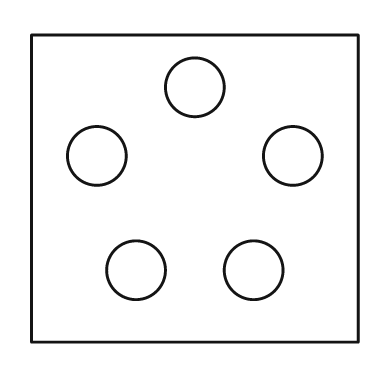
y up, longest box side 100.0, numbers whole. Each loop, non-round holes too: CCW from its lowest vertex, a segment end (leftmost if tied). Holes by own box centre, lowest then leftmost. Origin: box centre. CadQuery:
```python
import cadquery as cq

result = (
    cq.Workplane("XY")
    .moveTo(-50.0, -47.0)
    .lineTo(50.0, -47.0)
    .lineTo(50.0, 47.0)
    .lineTo(-50.0, 47.0)
    .close()
    .moveTo(-18.0, -25.0)
    .circle(9.0)
    .moveTo(18.0, -25.0)
    .circle(9.0)
    .moveTo(-30.0, 10.0)
    .circle(9.0)
    .moveTo(30.0, 10.0)
    .circle(9.0)
    .moveTo(0.0, 31.0)
    .circle(9.0)
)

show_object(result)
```